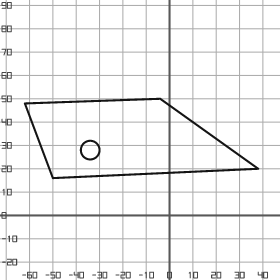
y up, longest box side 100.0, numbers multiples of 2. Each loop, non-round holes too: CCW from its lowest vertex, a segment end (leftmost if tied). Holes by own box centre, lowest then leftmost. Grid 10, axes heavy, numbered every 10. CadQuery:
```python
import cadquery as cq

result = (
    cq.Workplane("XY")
    .moveTo(-50.0, 16.0)
    .lineTo(38.0, 20.0)
    .lineTo(-4.0, 50.0)
    .lineTo(-62.0, 48.0)
    .close()
    .moveTo(-34.0, 28.0)
    .circle(4.0)
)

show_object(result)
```